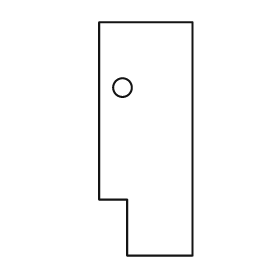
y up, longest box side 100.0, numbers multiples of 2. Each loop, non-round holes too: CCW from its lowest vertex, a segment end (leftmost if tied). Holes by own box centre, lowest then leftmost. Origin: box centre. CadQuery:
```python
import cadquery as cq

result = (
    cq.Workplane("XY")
    .moveTo(-8.0, -50.0)
    .lineTo(20.0, -50.0)
    .lineTo(20.0, 50.0)
    .lineTo(-20.0, 50.0)
    .lineTo(-20.0, -26.0)
    .lineTo(-8.0, -26.0)
    .close()
    .moveTo(-10.0, 22.0)
    .circle(4.0)
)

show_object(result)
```